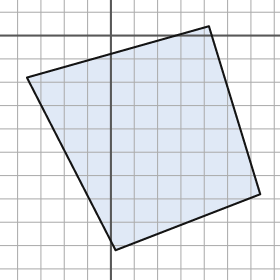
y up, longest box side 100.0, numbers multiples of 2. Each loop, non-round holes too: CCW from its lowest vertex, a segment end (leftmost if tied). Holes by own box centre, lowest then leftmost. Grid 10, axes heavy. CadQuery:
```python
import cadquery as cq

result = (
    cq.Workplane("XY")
    .moveTo(2.0, -92.0)
    .lineTo(64.0, -68.0)
    .lineTo(42.0, 4.0)
    .lineTo(-36.0, -18.0)
    .close()
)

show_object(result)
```